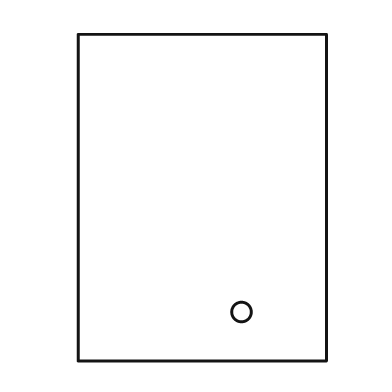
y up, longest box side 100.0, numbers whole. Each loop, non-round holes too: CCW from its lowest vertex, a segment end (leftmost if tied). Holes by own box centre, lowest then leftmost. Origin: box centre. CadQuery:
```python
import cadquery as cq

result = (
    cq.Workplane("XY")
    .moveTo(-38.0, -50.0)
    .lineTo(38.0, -50.0)
    .lineTo(38.0, 50.0)
    .lineTo(-38.0, 50.0)
    .close()
    .moveTo(12.0, -35.0)
    .circle(3.0)
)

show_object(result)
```